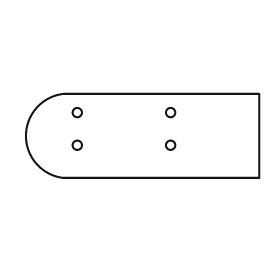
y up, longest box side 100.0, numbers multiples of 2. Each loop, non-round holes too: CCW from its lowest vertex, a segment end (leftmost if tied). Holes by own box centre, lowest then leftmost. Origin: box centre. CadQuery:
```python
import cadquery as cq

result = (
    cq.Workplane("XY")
    .moveTo(-34.0, -18.0)
    .lineTo(50.0, -18.0)
    .lineTo(50.0, 18.0)
    .lineTo(-34.0, 18.0)
    .threePointArc((-50.0, 0.0), (-34.0, -18.0))
    .close()
    .moveTo(-28.0, -4.0)
    .circle(2.0)
    .moveTo(12.0, -4.0)
    .circle(2.0)
    .moveTo(-28.0, 10.0)
    .circle(2.0)
    .moveTo(12.0, 10.0)
    .circle(2.0)
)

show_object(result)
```